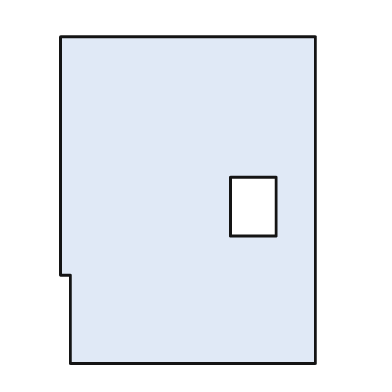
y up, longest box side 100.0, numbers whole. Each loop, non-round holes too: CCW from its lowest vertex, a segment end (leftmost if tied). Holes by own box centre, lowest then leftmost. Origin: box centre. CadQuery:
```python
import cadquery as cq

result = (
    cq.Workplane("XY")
    .moveTo(-36.0, -50.0)
    .lineTo(39.0, -50.0)
    .lineTo(39.0, 50.0)
    .lineTo(-39.0, 50.0)
    .lineTo(-39.0, -23.0)
    .lineTo(-36.0, -23.0)
    .close()
    .moveTo(13.0, -11.0)
    .lineTo(27.0, -11.0)
    .lineTo(27.0, 7.0)
    .lineTo(13.0, 7.0)
    .close()
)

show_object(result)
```